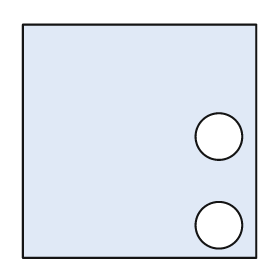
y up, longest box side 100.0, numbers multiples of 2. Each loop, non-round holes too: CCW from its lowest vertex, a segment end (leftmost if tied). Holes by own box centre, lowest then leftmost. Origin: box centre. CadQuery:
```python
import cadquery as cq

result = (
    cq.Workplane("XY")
    .moveTo(-50.0, -50.0)
    .lineTo(50.0, -50.0)
    .lineTo(50.0, 50.0)
    .lineTo(-50.0, 50.0)
    .close()
    .moveTo(34.0, -36.0)
    .circle(10.0)
    .moveTo(34.0, 2.0)
    .circle(10.0)
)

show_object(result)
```